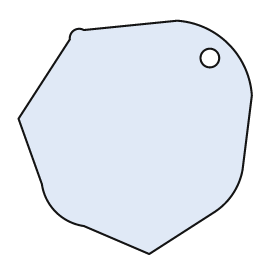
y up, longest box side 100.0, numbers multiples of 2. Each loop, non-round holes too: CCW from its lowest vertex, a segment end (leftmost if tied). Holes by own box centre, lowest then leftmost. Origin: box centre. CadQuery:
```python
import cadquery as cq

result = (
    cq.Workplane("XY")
    .moveTo(6.0, -50.0)
    .lineTo(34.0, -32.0)
    .threePointArc((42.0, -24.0), (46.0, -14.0))
    .lineTo(50.0, 18.0)
    .threePointArc((40.0, 40.0), (18.0, 50.0))
    .lineTo(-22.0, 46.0)
    .threePointArc((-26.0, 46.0), (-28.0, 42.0))
    .lineTo(-50.0, 8.0)
    .lineTo(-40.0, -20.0)
    .threePointArc((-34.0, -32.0), (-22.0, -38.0))
    .close()
    .moveTo(32.0, 34.0)
    .circle(4.0)
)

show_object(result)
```